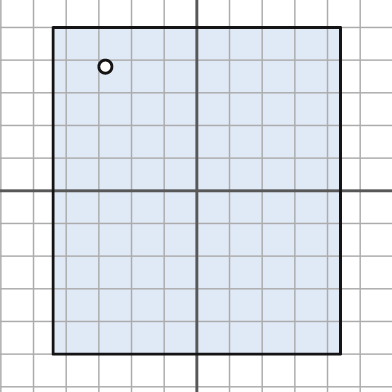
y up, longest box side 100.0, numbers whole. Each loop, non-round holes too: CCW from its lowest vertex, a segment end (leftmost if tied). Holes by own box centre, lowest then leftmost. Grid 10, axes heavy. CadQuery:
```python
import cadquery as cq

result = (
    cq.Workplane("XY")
    .moveTo(-44.0, -50.0)
    .lineTo(44.0, -50.0)
    .lineTo(44.0, 50.0)
    .lineTo(-44.0, 50.0)
    .close()
    .moveTo(-28.0, 38.0)
    .circle(2.0)
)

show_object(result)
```